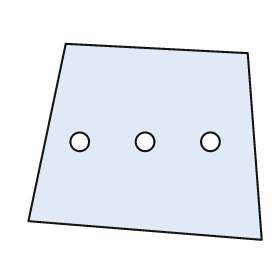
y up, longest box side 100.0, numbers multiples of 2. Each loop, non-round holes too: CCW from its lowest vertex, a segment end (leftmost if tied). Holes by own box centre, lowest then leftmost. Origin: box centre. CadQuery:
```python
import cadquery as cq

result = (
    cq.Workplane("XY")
    .moveTo(50.0, -42.0)
    .lineTo(44.0, 38.0)
    .lineTo(-34.0, 42.0)
    .lineTo(-50.0, -34.0)
    .close()
    .moveTo(-28.0, 0.0)
    .circle(4.0)
    .moveTo(0.0, 0.0)
    .circle(4.0)
    .moveTo(28.0, 0.0)
    .circle(4.0)
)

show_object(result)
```